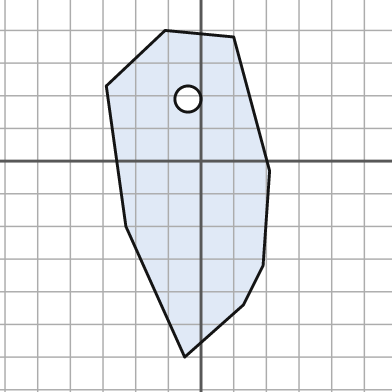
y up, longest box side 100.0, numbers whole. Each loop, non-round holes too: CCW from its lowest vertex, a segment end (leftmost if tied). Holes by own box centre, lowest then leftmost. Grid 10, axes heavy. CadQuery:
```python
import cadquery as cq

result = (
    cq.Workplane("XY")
    .moveTo(-5.0, -60.0)
    .lineTo(13.0, -44.0)
    .lineTo(19.0, -32.0)
    .lineTo(21.0, -3.0)
    .lineTo(10.0, 38.0)
    .lineTo(-11.0, 40.0)
    .lineTo(-29.0, 23.0)
    .lineTo(-23.0, -20.0)
    .close()
    .moveTo(-4.0, 19.0)
    .circle(4.0)
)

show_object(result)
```